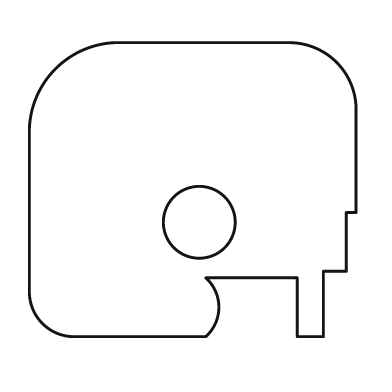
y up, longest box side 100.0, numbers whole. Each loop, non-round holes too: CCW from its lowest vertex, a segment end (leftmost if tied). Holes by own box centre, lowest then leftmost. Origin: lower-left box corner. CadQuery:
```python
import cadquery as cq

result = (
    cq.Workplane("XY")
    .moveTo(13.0, 0.0)
    .lineTo(54.0, 0.0)
    .threePointArc((58.0, 9.0), (54.0, 18.0))
    .lineTo(82.0, 18.0)
    .lineTo(82.0, 0.0)
    .lineTo(90.0, 0.0)
    .lineTo(90.0, 20.0)
    .lineTo(97.0, 20.0)
    .lineTo(97.0, 38.0)
    .lineTo(100.0, 38.0)
    .lineTo(100.0, 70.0)
    .threePointArc((94.0, 84.0), (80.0, 90.0))
    .lineTo(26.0, 90.0)
    .threePointArc((8.0, 82.0), (0.0, 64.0))
    .lineTo(0.0, 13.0)
    .threePointArc((4.0, 4.0), (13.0, 0.0))
    .close()
    .moveTo(52.0, 35.0)
    .circle(11.0)
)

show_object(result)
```